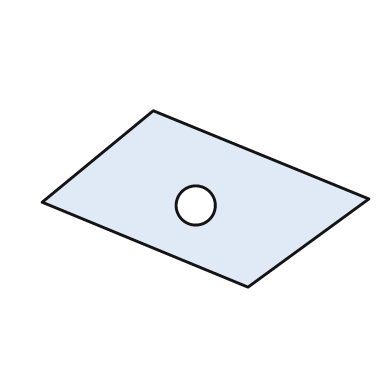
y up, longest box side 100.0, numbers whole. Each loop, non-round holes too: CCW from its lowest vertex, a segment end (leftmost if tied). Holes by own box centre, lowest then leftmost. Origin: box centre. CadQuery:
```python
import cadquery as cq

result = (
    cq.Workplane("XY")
    .moveTo(13.0, -27.0)
    .lineTo(50.0, 0.0)
    .lineTo(-16.0, 27.0)
    .lineTo(-50.0, -1.0)
    .close()
    .moveTo(-3.0, -2.0)
    .circle(6.0)
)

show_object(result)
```